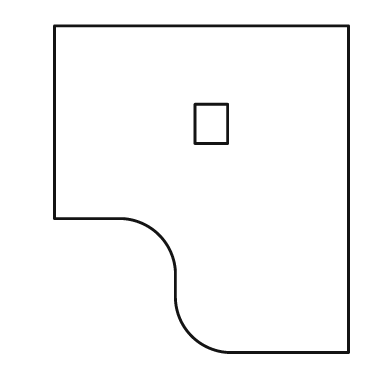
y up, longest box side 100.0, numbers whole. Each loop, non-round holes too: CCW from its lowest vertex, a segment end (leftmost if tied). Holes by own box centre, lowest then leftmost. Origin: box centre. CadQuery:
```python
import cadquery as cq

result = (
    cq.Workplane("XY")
    .moveTo(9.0, -50.0)
    .lineTo(45.0, -50.0)
    .lineTo(45.0, 50.0)
    .lineTo(-45.0, 50.0)
    .lineTo(-45.0, -9.0)
    .lineTo(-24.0, -9.0)
    .threePointArc((-13.0, -14.0), (-8.0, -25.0))
    .lineTo(-8.0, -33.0)
    .threePointArc((-3.0, -45.0), (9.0, -50.0))
    .close()
    .moveTo(-2.0, 14.0)
    .lineTo(8.0, 14.0)
    .lineTo(8.0, 26.0)
    .lineTo(-2.0, 26.0)
    .close()
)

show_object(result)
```